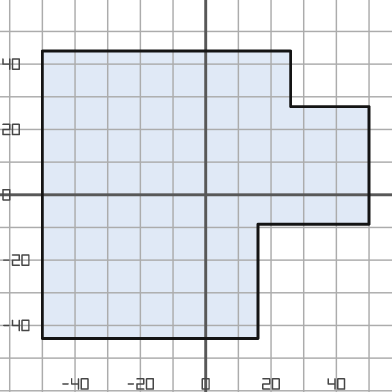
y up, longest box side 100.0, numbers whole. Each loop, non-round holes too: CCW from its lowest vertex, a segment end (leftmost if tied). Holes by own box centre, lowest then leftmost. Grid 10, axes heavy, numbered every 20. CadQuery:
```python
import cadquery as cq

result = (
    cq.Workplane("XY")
    .moveTo(-50.0, -44.0)
    .lineTo(16.0, -44.0)
    .lineTo(16.0, -9.0)
    .lineTo(50.0, -9.0)
    .lineTo(50.0, 27.0)
    .lineTo(26.0, 27.0)
    .lineTo(26.0, 44.0)
    .lineTo(-50.0, 44.0)
    .close()
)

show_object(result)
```